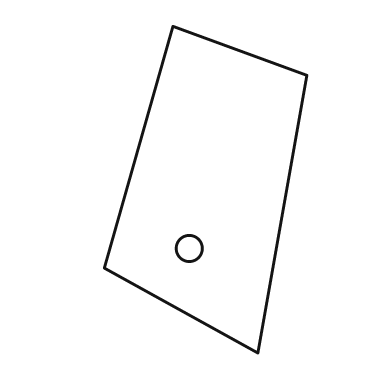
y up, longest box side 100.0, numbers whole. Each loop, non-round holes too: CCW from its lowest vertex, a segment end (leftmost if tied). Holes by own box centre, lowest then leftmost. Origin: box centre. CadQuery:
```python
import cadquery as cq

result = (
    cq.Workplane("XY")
    .moveTo(16.0, -50.0)
    .lineTo(31.0, 35.0)
    .lineTo(-10.0, 50.0)
    .lineTo(-31.0, -24.0)
    .close()
    .moveTo(-5.0, -18.0)
    .circle(4.0)
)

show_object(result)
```